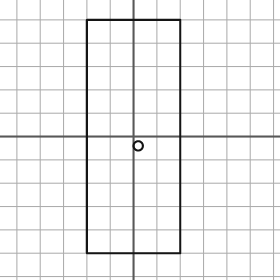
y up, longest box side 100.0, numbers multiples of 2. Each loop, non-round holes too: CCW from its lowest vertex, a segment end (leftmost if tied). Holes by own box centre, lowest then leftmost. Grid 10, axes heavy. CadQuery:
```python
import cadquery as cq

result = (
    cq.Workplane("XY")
    .moveTo(-20.0, -50.0)
    .lineTo(20.0, -50.0)
    .lineTo(20.0, 50.0)
    .lineTo(-20.0, 50.0)
    .close()
    .moveTo(2.0, -4.0)
    .circle(2.0)
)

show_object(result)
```